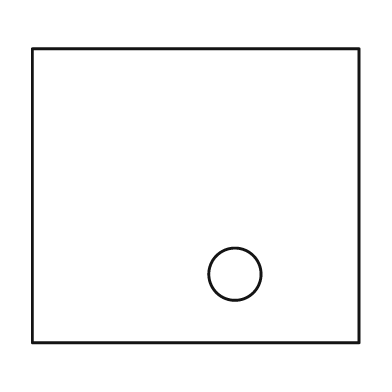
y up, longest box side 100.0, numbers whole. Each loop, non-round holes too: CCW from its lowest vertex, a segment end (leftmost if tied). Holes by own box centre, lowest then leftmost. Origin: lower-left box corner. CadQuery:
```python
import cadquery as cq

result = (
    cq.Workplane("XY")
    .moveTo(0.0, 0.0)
    .lineTo(100.0, 0.0)
    .lineTo(100.0, 90.0)
    .lineTo(0.0, 90.0)
    .close()
    .moveTo(62.0, 21.0)
    .circle(8.0)
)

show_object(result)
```